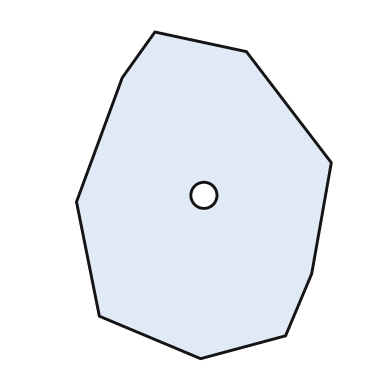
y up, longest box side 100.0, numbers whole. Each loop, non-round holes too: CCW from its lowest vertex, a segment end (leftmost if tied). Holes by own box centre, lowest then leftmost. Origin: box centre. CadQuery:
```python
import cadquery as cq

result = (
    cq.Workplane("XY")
    .moveTo(-1.0, -50.0)
    .lineTo(25.0, -43.0)
    .lineTo(33.0, -24.0)
    .lineTo(39.0, 10.0)
    .lineTo(13.0, 44.0)
    .lineTo(-15.0, 50.0)
    .lineTo(-25.0, 36.0)
    .lineTo(-39.0, -2.0)
    .lineTo(-32.0, -37.0)
    .close()
    .moveTo(0.0, 0.0)
    .circle(4.0)
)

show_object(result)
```